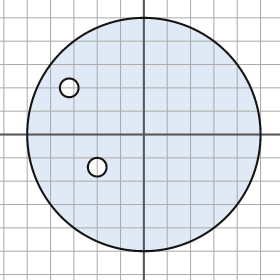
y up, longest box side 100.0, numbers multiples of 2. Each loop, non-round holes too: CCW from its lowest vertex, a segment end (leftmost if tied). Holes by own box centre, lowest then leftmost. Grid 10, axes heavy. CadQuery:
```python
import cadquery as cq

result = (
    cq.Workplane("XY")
    .moveTo(0.0, 0.0)
    .circle(50.0)
    .moveTo(-20.0, -14.0)
    .circle(4.0)
    .moveTo(-32.0, 20.0)
    .circle(4.0)
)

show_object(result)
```